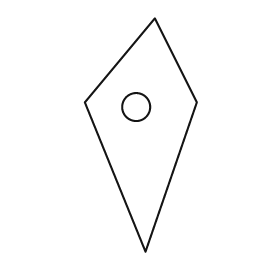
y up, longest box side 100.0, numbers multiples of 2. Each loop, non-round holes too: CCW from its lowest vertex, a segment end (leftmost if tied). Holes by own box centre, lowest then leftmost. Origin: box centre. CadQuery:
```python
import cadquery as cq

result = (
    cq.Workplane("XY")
    .moveTo(2.0, -50.0)
    .lineTo(24.0, 14.0)
    .lineTo(6.0, 50.0)
    .lineTo(-24.0, 14.0)
    .close()
    .moveTo(-2.0, 12.0)
    .circle(6.0)
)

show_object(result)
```